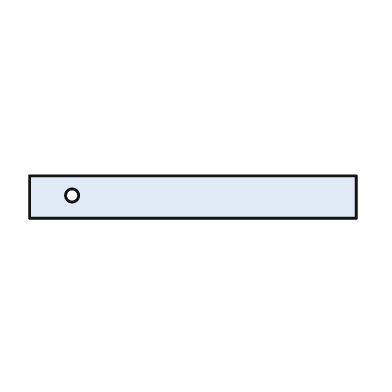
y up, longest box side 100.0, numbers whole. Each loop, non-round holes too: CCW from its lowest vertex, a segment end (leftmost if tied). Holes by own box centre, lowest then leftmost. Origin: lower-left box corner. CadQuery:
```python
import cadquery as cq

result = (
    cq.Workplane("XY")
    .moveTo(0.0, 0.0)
    .lineTo(100.0, 0.0)
    .lineTo(100.0, 13.0)
    .lineTo(0.0, 13.0)
    .close()
    .moveTo(13.0, 7.0)
    .circle(2.0)
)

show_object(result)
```